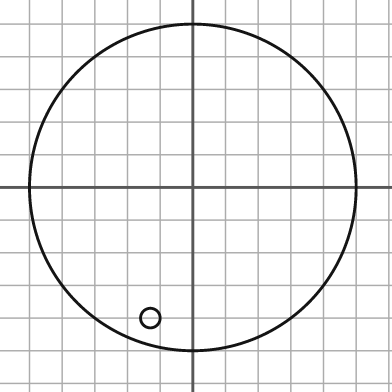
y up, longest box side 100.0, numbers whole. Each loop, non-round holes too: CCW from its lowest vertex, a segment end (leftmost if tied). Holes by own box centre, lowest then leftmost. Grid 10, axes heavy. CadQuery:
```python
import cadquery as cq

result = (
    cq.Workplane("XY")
    .moveTo(0.0, 0.0)
    .circle(50.0)
    .moveTo(-13.0, -40.0)
    .circle(3.0)
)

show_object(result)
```